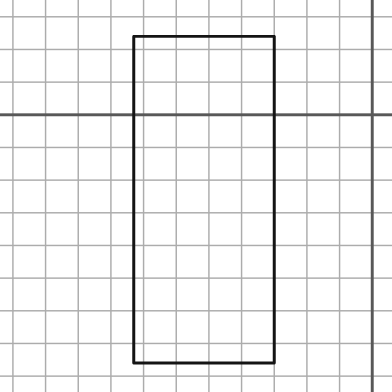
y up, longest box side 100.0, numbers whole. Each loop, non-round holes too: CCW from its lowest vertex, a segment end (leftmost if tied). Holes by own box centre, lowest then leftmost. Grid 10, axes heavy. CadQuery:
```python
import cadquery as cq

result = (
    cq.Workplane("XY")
    .moveTo(-73.0, -76.0)
    .lineTo(-30.0, -76.0)
    .lineTo(-30.0, 24.0)
    .lineTo(-73.0, 24.0)
    .close()
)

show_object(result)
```